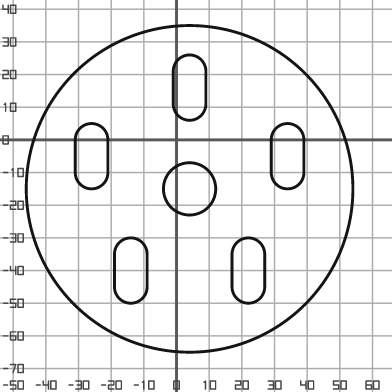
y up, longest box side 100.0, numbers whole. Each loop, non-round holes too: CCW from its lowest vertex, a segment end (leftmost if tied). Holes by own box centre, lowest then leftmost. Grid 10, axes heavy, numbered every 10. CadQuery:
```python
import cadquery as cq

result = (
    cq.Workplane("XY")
    .moveTo(4.0, -15.0)
    .circle(50.0)
    .moveTo(-19.0, -45.0)
    .threePointArc((-14.0, -50.0), (-9.0, -45.0))
    .lineTo(-9.0, -35.0)
    .threePointArc((-14.0, -30.0), (-19.0, -35.0))
    .close()
    .moveTo(17.0, -45.0)
    .threePointArc((22.0, -50.0), (27.0, -45.0))
    .lineTo(27.0, -35.0)
    .threePointArc((22.0, -30.0), (17.0, -35.0))
    .close()
    .moveTo(4.0, -15.0)
    .circle(8.0)
    .moveTo(-31.0, -10.0)
    .threePointArc((-26.0, -15.0), (-21.0, -10.0))
    .lineTo(-21.0, 0.0)
    .threePointArc((-26.0, 5.0), (-31.0, 0.0))
    .close()
    .moveTo(29.0, -10.0)
    .threePointArc((34.0, -15.0), (39.0, -10.0))
    .lineTo(39.0, 0.0)
    .threePointArc((34.0, 5.0), (29.0, 0.0))
    .close()
    .moveTo(-1.0, 11.0)
    .threePointArc((4.0, 6.0), (9.0, 11.0))
    .lineTo(9.0, 21.0)
    .threePointArc((4.0, 26.0), (-1.0, 21.0))
    .close()
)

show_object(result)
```